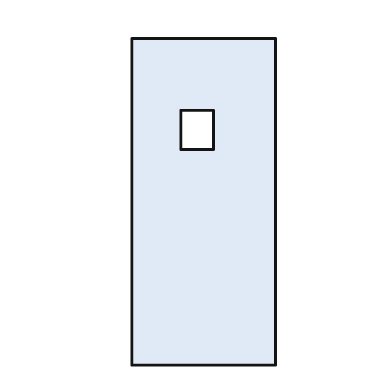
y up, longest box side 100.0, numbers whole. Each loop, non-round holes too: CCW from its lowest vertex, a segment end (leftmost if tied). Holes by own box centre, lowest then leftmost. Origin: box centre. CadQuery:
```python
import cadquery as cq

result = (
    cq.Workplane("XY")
    .moveTo(-22.0, -50.0)
    .lineTo(22.0, -50.0)
    .lineTo(22.0, 50.0)
    .lineTo(-22.0, 50.0)
    .close()
    .moveTo(-7.0, 16.0)
    .lineTo(3.0, 16.0)
    .lineTo(3.0, 28.0)
    .lineTo(-7.0, 28.0)
    .close()
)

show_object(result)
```